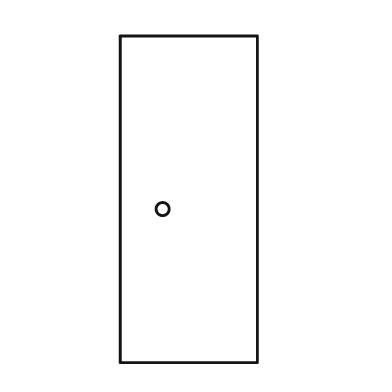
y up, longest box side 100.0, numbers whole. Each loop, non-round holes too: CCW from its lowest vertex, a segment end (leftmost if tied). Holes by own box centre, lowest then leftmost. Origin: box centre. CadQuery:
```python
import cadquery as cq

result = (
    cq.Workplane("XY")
    .moveTo(-21.0, -50.0)
    .lineTo(21.0, -50.0)
    .lineTo(21.0, 50.0)
    .lineTo(-21.0, 50.0)
    .close()
    .moveTo(-8.0, -3.0)
    .circle(2.0)
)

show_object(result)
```